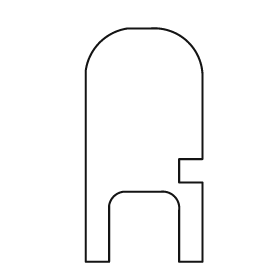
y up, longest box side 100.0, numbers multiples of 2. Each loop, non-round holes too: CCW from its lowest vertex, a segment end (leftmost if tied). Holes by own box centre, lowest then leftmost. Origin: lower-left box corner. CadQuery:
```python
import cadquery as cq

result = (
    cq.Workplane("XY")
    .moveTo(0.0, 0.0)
    .lineTo(10.0, 0.0)
    .lineTo(10.0, 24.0)
    .threePointArc((12.0, 28.0), (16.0, 30.0))
    .lineTo(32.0, 30.0)
    .threePointArc((38.0, 28.0), (40.0, 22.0))
    .lineTo(40.0, 0.0)
    .lineTo(50.0, 0.0)
    .lineTo(50.0, 34.0)
    .lineTo(40.0, 34.0)
    .lineTo(40.0, 44.0)
    .lineTo(50.0, 44.0)
    .lineTo(50.0, 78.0)
    .threePointArc((44.0, 94.0), (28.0, 100.0))
    .lineTo(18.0, 100.0)
    .threePointArc((6.0, 94.0), (0.0, 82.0))
    .close()
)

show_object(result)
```